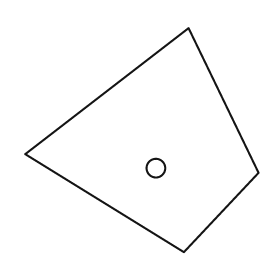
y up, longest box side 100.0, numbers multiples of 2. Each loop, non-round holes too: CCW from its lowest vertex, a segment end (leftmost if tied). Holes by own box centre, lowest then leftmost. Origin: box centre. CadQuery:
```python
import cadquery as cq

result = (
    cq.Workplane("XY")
    .moveTo(18.0, -48.0)
    .lineTo(50.0, -14.0)
    .lineTo(20.0, 48.0)
    .lineTo(-50.0, -6.0)
    .close()
    .moveTo(6.0, -12.0)
    .circle(4.0)
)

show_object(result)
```